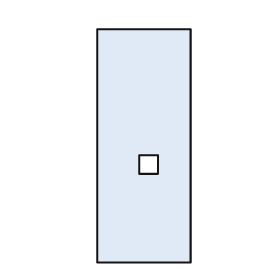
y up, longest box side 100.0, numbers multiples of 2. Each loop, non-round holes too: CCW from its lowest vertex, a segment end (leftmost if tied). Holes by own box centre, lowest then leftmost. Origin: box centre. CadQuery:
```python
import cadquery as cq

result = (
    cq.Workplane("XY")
    .moveTo(-20.0, -50.0)
    .lineTo(20.0, -50.0)
    .lineTo(20.0, 50.0)
    .lineTo(-20.0, 50.0)
    .close()
    .moveTo(-2.0, -12.0)
    .lineTo(6.0, -12.0)
    .lineTo(6.0, -4.0)
    .lineTo(-2.0, -4.0)
    .close()
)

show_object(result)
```